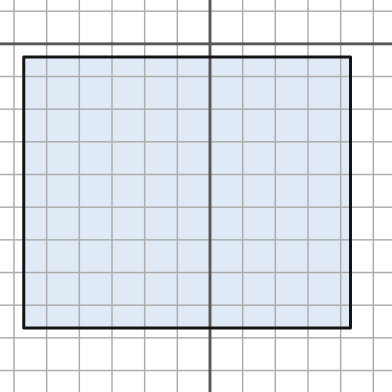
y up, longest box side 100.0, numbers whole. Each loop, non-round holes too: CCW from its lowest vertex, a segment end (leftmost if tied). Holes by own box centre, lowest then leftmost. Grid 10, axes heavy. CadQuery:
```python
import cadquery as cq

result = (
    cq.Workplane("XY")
    .moveTo(-57.0, -87.0)
    .lineTo(43.0, -87.0)
    .lineTo(43.0, -4.0)
    .lineTo(-57.0, -4.0)
    .close()
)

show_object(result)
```